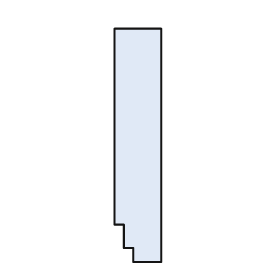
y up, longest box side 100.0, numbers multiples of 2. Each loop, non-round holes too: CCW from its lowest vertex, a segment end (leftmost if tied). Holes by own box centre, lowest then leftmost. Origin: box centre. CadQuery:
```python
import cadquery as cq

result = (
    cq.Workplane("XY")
    .moveTo(-2.0, -50.0)
    .lineTo(10.0, -50.0)
    .lineTo(10.0, 50.0)
    .lineTo(-10.0, 50.0)
    .lineTo(-10.0, -34.0)
    .lineTo(-6.0, -34.0)
    .lineTo(-6.0, -44.0)
    .lineTo(-2.0, -44.0)
    .close()
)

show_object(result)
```